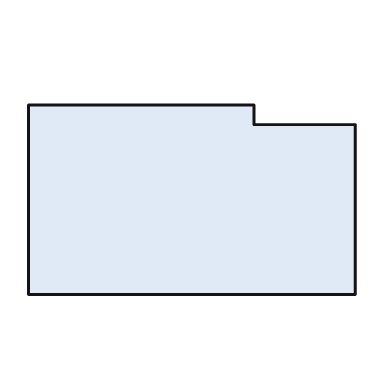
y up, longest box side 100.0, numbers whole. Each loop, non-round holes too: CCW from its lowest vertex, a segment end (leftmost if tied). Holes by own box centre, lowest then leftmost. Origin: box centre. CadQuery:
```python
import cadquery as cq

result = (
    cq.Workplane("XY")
    .moveTo(-50.0, -29.0)
    .lineTo(50.0, -29.0)
    .lineTo(50.0, 23.0)
    .lineTo(19.0, 23.0)
    .lineTo(19.0, 29.0)
    .lineTo(-50.0, 29.0)
    .close()
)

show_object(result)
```